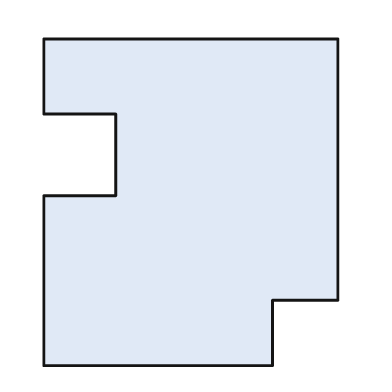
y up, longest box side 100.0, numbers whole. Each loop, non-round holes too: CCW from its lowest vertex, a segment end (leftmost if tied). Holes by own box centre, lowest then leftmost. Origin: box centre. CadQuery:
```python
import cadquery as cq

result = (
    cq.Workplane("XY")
    .moveTo(-45.0, -50.0)
    .lineTo(25.0, -50.0)
    .lineTo(25.0, -30.0)
    .lineTo(45.0, -30.0)
    .lineTo(45.0, 50.0)
    .lineTo(-45.0, 50.0)
    .lineTo(-45.0, 27.0)
    .lineTo(-23.0, 27.0)
    .lineTo(-23.0, 2.0)
    .lineTo(-45.0, 2.0)
    .close()
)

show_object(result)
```